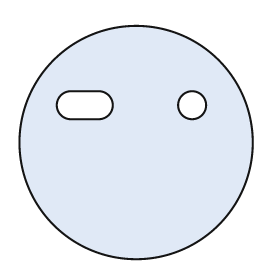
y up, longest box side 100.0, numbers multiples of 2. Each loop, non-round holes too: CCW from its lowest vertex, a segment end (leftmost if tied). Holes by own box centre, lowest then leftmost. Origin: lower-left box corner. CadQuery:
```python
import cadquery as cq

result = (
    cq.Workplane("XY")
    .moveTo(50.0, 50.0)
    .circle(50.0)
    .moveTo(22.0, 60.0)
    .lineTo(34.0, 60.0)
    .threePointArc((40.0, 66.0), (34.0, 72.0))
    .lineTo(22.0, 72.0)
    .threePointArc((16.0, 66.0), (22.0, 60.0))
    .close()
    .moveTo(74.0, 66.0)
    .circle(6.0)
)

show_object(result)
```